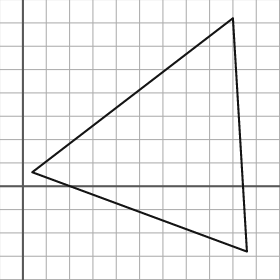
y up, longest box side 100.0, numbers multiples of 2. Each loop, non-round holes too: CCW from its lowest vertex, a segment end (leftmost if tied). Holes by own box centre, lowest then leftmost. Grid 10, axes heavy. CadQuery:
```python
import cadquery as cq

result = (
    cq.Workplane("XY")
    .moveTo(96.0, -28.0)
    .lineTo(90.0, 72.0)
    .lineTo(4.0, 6.0)
    .close()
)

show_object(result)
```